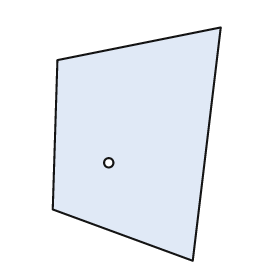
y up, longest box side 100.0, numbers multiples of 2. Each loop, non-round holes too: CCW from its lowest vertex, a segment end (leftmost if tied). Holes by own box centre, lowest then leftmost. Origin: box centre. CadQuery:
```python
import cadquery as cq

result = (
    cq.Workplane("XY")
    .moveTo(24.0, -50.0)
    .lineTo(36.0, 50.0)
    .lineTo(-34.0, 36.0)
    .lineTo(-36.0, -28.0)
    .close()
    .moveTo(-12.0, -8.0)
    .circle(2.0)
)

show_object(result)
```